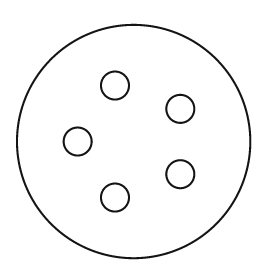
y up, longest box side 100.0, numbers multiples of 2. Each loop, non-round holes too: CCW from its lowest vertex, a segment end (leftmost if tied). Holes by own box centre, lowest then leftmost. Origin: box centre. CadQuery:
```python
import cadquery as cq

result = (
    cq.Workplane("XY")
    .moveTo(0.0, 0.0)
    .circle(50.0)
    .moveTo(-8.0, -24.0)
    .circle(6.0)
    .moveTo(20.0, -14.0)
    .circle(6.0)
    .moveTo(-24.0, 0.0)
    .circle(6.0)
    .moveTo(20.0, 14.0)
    .circle(6.0)
    .moveTo(-8.0, 24.0)
    .circle(6.0)
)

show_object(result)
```